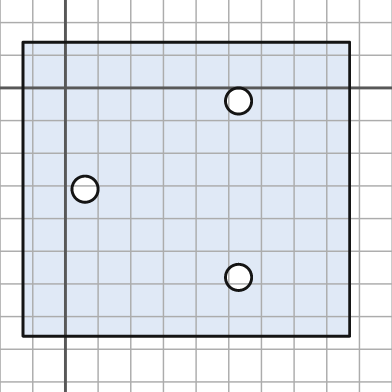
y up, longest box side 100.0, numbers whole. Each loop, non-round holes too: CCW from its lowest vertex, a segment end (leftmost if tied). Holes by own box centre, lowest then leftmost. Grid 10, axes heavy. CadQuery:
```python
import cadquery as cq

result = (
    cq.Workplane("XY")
    .moveTo(-13.0, -76.0)
    .lineTo(87.0, -76.0)
    .lineTo(87.0, 14.0)
    .lineTo(-13.0, 14.0)
    .close()
    .moveTo(53.0, -58.0)
    .circle(4.0)
    .moveTo(6.0, -31.0)
    .circle(4.0)
    .moveTo(53.0, -4.0)
    .circle(4.0)
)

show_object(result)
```